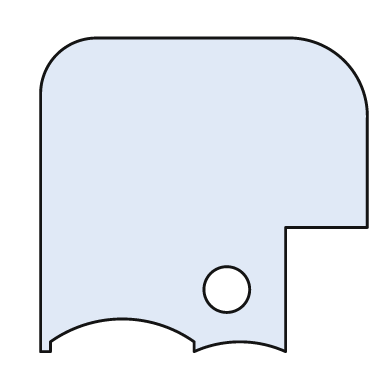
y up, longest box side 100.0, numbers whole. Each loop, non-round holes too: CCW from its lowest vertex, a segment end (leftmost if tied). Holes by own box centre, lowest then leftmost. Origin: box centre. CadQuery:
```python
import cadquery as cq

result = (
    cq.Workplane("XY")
    .moveTo(-50.0, -48.0)
    .lineTo(-47.0, -48.0)
    .lineTo(-47.0, -45.0)
    .threePointArc((-25.0, -38.0), (-3.0, -45.0))
    .lineTo(-3.0, -48.0)
    .threePointArc((11.0, -45.0), (25.0, -48.0))
    .lineTo(25.0, -10.0)
    .lineTo(50.0, -10.0)
    .lineTo(50.0, 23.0)
    .threePointArc((43.0, 41.0), (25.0, 48.0))
    .lineTo(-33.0, 48.0)
    .threePointArc((-45.0, 43.0), (-50.0, 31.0))
    .close()
    .moveTo(7.0, -29.0)
    .circle(7.0)
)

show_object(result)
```